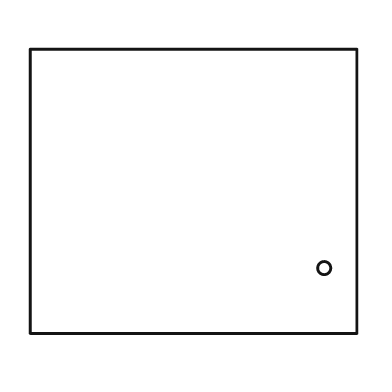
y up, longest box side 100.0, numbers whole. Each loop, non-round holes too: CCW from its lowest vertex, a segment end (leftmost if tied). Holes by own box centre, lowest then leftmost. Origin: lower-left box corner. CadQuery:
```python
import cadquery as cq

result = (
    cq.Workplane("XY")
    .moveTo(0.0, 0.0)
    .lineTo(100.0, 0.0)
    .lineTo(100.0, 87.0)
    .lineTo(0.0, 87.0)
    .close()
    .moveTo(90.0, 20.0)
    .circle(2.0)
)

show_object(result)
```